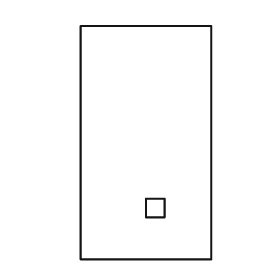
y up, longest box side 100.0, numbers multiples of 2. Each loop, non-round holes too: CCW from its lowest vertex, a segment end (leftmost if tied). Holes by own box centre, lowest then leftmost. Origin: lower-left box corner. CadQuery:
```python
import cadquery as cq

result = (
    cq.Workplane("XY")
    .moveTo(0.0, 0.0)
    .lineTo(56.0, 0.0)
    .lineTo(56.0, 100.0)
    .lineTo(0.0, 100.0)
    .close()
    .moveTo(28.0, 18.0)
    .lineTo(36.0, 18.0)
    .lineTo(36.0, 26.0)
    .lineTo(28.0, 26.0)
    .close()
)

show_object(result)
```